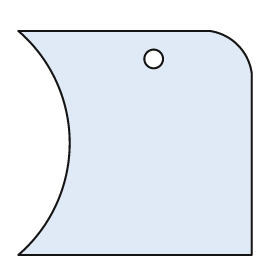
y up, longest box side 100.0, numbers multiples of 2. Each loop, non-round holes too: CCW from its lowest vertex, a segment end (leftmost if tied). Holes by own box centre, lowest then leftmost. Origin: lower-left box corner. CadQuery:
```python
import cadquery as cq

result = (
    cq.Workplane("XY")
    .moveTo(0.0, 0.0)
    .lineTo(100.0, 0.0)
    .lineTo(100.0, 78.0)
    .threePointArc((94.0, 90.0), (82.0, 96.0))
    .lineTo(0.0, 96.0)
    .threePointArc((22.0, 48.0), (0.0, 0.0))
    .close()
    .moveTo(58.0, 84.0)
    .circle(4.0)
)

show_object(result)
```